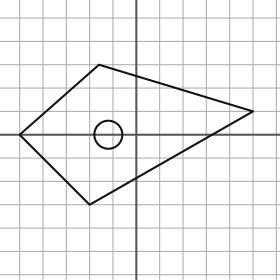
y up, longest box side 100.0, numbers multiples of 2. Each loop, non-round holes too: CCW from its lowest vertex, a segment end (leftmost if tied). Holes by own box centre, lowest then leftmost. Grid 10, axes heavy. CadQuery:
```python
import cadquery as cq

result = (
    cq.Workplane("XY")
    .moveTo(-20.0, -30.0)
    .lineTo(50.0, 10.0)
    .lineTo(-16.0, 30.0)
    .lineTo(-50.0, 0.0)
    .close()
    .moveTo(-12.0, 0.0)
    .circle(6.0)
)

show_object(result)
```